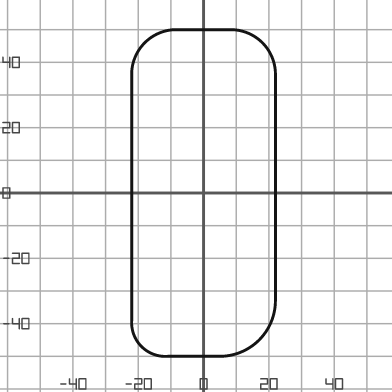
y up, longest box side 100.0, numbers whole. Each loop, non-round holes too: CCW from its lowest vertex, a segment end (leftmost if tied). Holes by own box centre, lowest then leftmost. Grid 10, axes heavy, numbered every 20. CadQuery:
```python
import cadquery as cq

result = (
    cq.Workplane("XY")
    .moveTo(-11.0, -50.0)
    .lineTo(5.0, -50.0)
    .threePointArc((17.0, -45.0), (22.0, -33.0))
    .lineTo(22.0, 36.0)
    .threePointArc((18.0, 46.0), (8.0, 50.0))
    .lineTo(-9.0, 50.0)
    .threePointArc((-18.0, 46.0), (-22.0, 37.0))
    .lineTo(-22.0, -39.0)
    .threePointArc((-19.0, -47.0), (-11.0, -50.0))
    .close()
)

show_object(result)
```